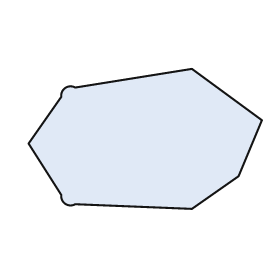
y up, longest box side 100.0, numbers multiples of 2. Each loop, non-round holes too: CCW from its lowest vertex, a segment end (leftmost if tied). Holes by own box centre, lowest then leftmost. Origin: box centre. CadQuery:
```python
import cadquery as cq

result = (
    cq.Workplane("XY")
    .moveTo(20.0, -30.0)
    .lineTo(40.0, -16.0)
    .lineTo(50.0, 8.0)
    .lineTo(20.0, 30.0)
    .lineTo(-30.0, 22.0)
    .threePointArc((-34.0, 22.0), (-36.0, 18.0))
    .lineTo(-50.0, -2.0)
    .lineTo(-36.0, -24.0)
    .threePointArc((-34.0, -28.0), (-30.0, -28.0))
    .close()
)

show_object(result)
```